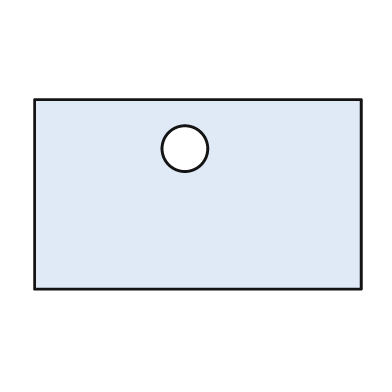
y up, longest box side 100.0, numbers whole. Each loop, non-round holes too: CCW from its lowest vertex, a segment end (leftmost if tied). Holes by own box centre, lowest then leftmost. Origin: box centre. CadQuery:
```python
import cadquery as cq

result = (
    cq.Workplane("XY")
    .moveTo(-50.0, -29.0)
    .lineTo(50.0, -29.0)
    .lineTo(50.0, 29.0)
    .lineTo(-50.0, 29.0)
    .close()
    .moveTo(-4.0, 14.0)
    .circle(7.0)
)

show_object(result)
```